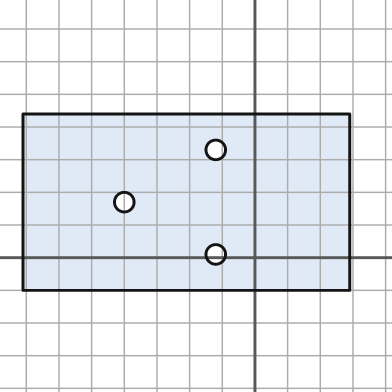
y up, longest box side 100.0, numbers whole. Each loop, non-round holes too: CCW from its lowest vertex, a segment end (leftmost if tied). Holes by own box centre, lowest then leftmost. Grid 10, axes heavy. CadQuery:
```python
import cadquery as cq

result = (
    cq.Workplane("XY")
    .moveTo(-71.0, -10.0)
    .lineTo(29.0, -10.0)
    .lineTo(29.0, 44.0)
    .lineTo(-71.0, 44.0)
    .close()
    .moveTo(-12.0, 1.0)
    .circle(3.0)
    .moveTo(-40.0, 17.0)
    .circle(3.0)
    .moveTo(-12.0, 33.0)
    .circle(3.0)
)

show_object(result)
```